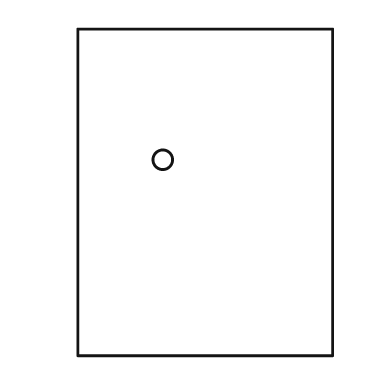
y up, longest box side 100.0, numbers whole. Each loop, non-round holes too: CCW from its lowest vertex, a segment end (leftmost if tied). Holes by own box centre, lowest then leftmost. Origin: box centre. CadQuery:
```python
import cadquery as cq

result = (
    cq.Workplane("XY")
    .moveTo(-39.0, -50.0)
    .lineTo(39.0, -50.0)
    .lineTo(39.0, 50.0)
    .lineTo(-39.0, 50.0)
    .close()
    .moveTo(-13.0, 10.0)
    .circle(3.0)
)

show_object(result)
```